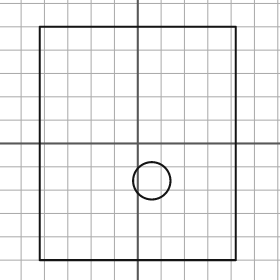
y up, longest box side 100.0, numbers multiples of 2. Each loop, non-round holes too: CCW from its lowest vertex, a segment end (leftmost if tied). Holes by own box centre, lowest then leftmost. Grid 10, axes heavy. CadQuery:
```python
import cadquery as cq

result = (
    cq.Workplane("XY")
    .moveTo(-42.0, -50.0)
    .lineTo(42.0, -50.0)
    .lineTo(42.0, 50.0)
    .lineTo(-42.0, 50.0)
    .close()
    .moveTo(6.0, -16.0)
    .circle(8.0)
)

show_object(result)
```